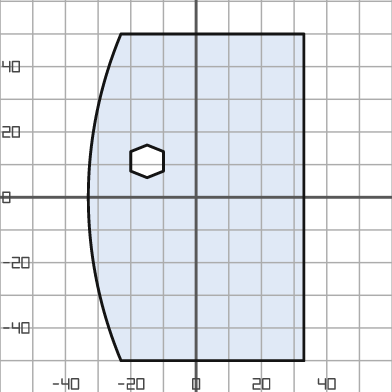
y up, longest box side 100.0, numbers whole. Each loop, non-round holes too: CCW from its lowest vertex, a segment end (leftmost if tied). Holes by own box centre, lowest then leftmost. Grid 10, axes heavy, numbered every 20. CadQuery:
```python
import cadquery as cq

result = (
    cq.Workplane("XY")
    .moveTo(-23.0, -50.0)
    .lineTo(33.0, -50.0)
    .lineTo(33.0, 50.0)
    .lineTo(-23.0, 50.0)
    .threePointArc((-33.0, 0.0), (-23.0, -50.0))
    .close()
    .moveTo(-15.0, 6.0)
    .lineTo(-10.0, 8.0)
    .lineTo(-10.0, 14.0)
    .lineTo(-15.0, 16.0)
    .lineTo(-20.0, 14.0)
    .lineTo(-20.0, 8.0)
    .close()
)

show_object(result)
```